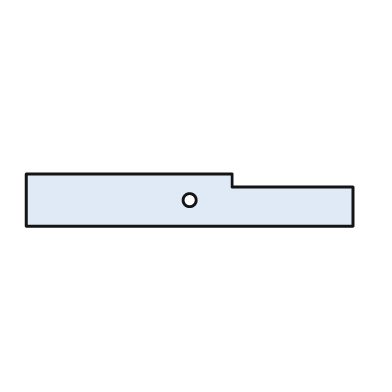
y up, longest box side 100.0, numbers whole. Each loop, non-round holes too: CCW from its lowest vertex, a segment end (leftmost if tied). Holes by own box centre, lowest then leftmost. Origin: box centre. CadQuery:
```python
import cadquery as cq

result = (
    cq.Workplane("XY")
    .moveTo(-50.0, -8.0)
    .lineTo(50.0, -8.0)
    .lineTo(50.0, 4.0)
    .lineTo(13.0, 4.0)
    .lineTo(13.0, 8.0)
    .lineTo(-50.0, 8.0)
    .close()
    .moveTo(0.0, 0.0)
    .circle(2.0)
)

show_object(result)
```